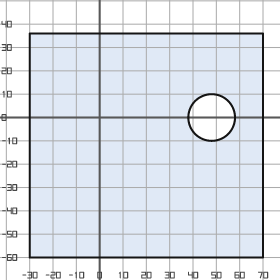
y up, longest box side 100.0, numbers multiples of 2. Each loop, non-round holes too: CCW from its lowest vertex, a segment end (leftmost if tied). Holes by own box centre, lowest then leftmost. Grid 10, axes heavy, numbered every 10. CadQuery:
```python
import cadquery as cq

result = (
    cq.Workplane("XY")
    .moveTo(-30.0, -60.0)
    .lineTo(70.0, -60.0)
    .lineTo(70.0, 36.0)
    .lineTo(-30.0, 36.0)
    .close()
    .moveTo(48.0, 0.0)
    .circle(10.0)
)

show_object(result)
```